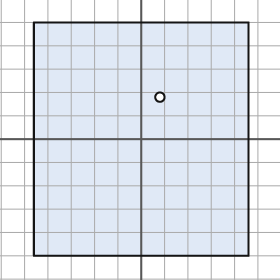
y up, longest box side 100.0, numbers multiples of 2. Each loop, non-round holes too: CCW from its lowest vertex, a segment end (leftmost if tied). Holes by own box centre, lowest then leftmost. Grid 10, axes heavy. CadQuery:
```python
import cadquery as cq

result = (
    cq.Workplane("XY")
    .moveTo(-46.0, -50.0)
    .lineTo(46.0, -50.0)
    .lineTo(46.0, 50.0)
    .lineTo(-46.0, 50.0)
    .close()
    .moveTo(8.0, 18.0)
    .circle(2.0)
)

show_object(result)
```